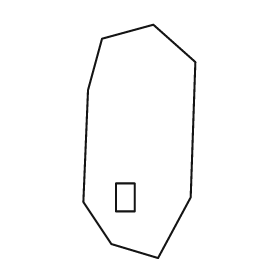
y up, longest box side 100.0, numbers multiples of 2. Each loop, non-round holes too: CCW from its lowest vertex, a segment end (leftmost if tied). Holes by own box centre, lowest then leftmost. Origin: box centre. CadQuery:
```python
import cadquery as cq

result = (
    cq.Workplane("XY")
    .moveTo(8.0, -50.0)
    .lineTo(22.0, -24.0)
    .lineTo(24.0, 34.0)
    .lineTo(6.0, 50.0)
    .lineTo(-16.0, 44.0)
    .lineTo(-22.0, 22.0)
    .lineTo(-24.0, -26.0)
    .lineTo(-12.0, -44.0)
    .close()
    .moveTo(-10.0, -30.0)
    .lineTo(-2.0, -30.0)
    .lineTo(-2.0, -18.0)
    .lineTo(-10.0, -18.0)
    .close()
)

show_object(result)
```